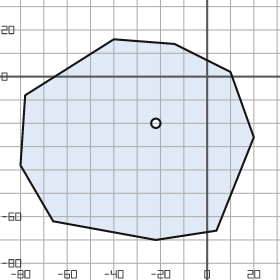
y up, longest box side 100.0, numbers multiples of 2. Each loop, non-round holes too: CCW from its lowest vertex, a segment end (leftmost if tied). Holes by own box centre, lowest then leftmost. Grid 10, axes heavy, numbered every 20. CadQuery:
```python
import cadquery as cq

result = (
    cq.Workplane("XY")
    .moveTo(-22.0, -70.0)
    .lineTo(4.0, -66.0)
    .lineTo(20.0, -26.0)
    .lineTo(10.0, 2.0)
    .lineTo(-14.0, 14.0)
    .lineTo(-40.0, 16.0)
    .lineTo(-78.0, -8.0)
    .lineTo(-80.0, -38.0)
    .lineTo(-66.0, -62.0)
    .close()
    .moveTo(-22.0, -20.0)
    .circle(2.0)
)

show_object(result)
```